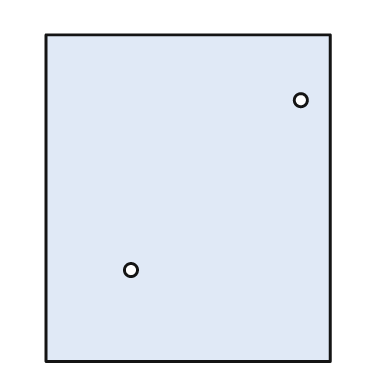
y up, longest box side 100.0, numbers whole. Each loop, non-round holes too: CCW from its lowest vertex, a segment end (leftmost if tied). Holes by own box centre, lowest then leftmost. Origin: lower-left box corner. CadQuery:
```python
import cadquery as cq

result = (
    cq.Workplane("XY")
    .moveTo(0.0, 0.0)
    .lineTo(87.0, 0.0)
    .lineTo(87.0, 100.0)
    .lineTo(0.0, 100.0)
    .close()
    .moveTo(26.0, 28.0)
    .circle(2.0)
    .moveTo(78.0, 80.0)
    .circle(2.0)
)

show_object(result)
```